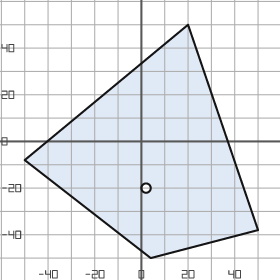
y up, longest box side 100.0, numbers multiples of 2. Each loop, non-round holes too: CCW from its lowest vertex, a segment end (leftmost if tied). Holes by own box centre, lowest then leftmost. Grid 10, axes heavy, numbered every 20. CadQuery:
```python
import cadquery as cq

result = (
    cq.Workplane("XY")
    .moveTo(4.0, -50.0)
    .lineTo(50.0, -38.0)
    .lineTo(20.0, 50.0)
    .lineTo(-50.0, -8.0)
    .close()
    .moveTo(2.0, -20.0)
    .circle(2.0)
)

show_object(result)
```